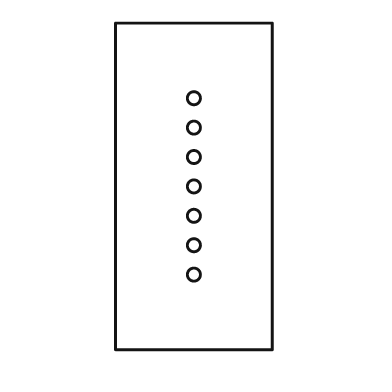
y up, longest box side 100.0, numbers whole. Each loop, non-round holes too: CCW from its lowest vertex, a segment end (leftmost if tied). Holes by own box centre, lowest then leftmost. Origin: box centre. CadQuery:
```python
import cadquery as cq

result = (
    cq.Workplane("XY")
    .moveTo(-24.0, -50.0)
    .lineTo(24.0, -50.0)
    .lineTo(24.0, 50.0)
    .lineTo(-24.0, 50.0)
    .close()
    .moveTo(0.0, -27.0)
    .circle(2.0)
    .moveTo(0.0, -18.0)
    .circle(2.0)
    .moveTo(0.0, -9.0)
    .circle(2.0)
    .moveTo(0.0, 0.0)
    .circle(2.0)
    .moveTo(0.0, 9.0)
    .circle(2.0)
    .moveTo(0.0, 18.0)
    .circle(2.0)
    .moveTo(0.0, 27.0)
    .circle(2.0)
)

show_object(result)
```